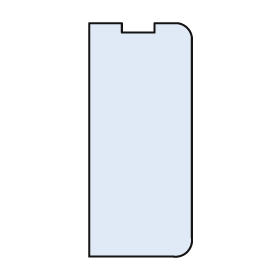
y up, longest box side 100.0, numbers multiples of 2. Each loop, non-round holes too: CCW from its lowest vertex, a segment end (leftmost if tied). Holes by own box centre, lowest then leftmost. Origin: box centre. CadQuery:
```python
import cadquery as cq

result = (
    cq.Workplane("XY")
    .moveTo(-22.0, -50.0)
    .lineTo(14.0, -50.0)
    .threePointArc((20.0, -48.0), (22.0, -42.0))
    .lineTo(22.0, 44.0)
    .threePointArc((20.0, 48.0), (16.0, 50.0))
    .lineTo(6.0, 50.0)
    .lineTo(6.0, 46.0)
    .lineTo(-8.0, 46.0)
    .lineTo(-8.0, 50.0)
    .lineTo(-22.0, 50.0)
    .close()
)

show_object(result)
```